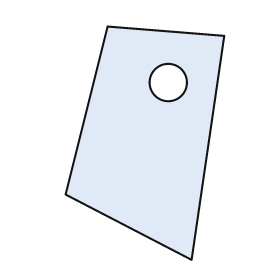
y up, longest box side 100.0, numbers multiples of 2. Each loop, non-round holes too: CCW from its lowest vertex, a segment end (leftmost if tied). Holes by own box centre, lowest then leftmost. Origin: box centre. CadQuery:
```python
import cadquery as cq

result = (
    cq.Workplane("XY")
    .moveTo(20.0, -50.0)
    .lineTo(34.0, 46.0)
    .lineTo(-16.0, 50.0)
    .lineTo(-34.0, -22.0)
    .close()
    .moveTo(10.0, 26.0)
    .circle(8.0)
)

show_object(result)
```